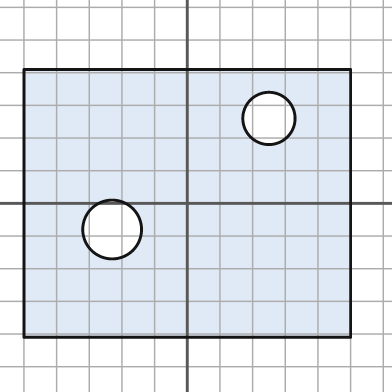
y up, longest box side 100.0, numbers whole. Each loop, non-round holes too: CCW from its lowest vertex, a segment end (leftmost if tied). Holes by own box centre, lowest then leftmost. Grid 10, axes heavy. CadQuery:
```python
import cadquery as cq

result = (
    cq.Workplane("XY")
    .moveTo(-50.0, -41.0)
    .lineTo(50.0, -41.0)
    .lineTo(50.0, 41.0)
    .lineTo(-50.0, 41.0)
    .close()
    .moveTo(-23.0, -8.0)
    .circle(9.0)
    .moveTo(25.0, 26.0)
    .circle(8.0)
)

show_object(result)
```